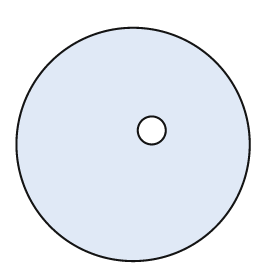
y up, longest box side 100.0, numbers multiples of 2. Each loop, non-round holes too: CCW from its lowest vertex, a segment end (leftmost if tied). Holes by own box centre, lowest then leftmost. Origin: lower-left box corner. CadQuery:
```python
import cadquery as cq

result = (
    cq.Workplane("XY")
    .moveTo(50.0, 50.0)
    .circle(50.0)
    .moveTo(58.0, 56.0)
    .circle(6.0)
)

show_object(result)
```